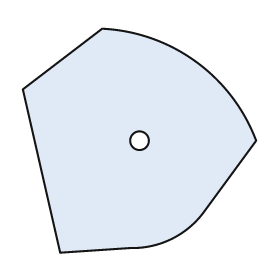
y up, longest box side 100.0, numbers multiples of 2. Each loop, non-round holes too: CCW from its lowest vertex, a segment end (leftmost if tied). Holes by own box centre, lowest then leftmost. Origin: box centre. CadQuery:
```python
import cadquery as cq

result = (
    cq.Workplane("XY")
    .moveTo(-34.0, -48.0)
    .lineTo(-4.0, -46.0)
    .threePointArc((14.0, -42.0), (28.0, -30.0))
    .lineTo(50.0, 0.0)
    .threePointArc((24.0, 34.0), (-16.0, 48.0))
    .lineTo(-50.0, 22.0)
    .close()
    .moveTo(0.0, 0.0)
    .circle(4.0)
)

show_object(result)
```